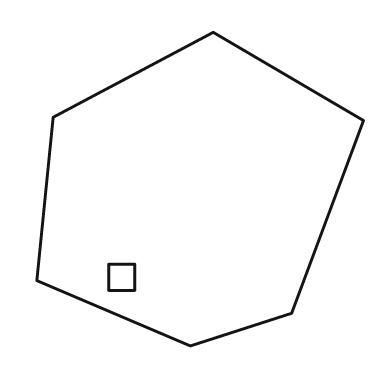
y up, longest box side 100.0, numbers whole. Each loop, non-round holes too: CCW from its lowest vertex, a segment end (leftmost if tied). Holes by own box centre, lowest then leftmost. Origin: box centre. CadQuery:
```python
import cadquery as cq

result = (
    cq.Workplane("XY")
    .moveTo(-3.0, -48.0)
    .lineTo(28.0, -38.0)
    .lineTo(50.0, 21.0)
    .lineTo(4.0, 48.0)
    .lineTo(-45.0, 22.0)
    .lineTo(-50.0, -28.0)
    .close()
    .moveTo(-28.0, -31.0)
    .lineTo(-20.0, -31.0)
    .lineTo(-20.0, -23.0)
    .lineTo(-28.0, -23.0)
    .close()
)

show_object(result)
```